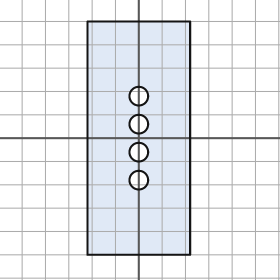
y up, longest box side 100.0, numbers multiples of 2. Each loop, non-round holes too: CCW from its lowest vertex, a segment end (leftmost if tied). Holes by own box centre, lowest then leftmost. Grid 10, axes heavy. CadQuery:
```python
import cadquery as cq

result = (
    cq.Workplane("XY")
    .moveTo(-22.0, -50.0)
    .lineTo(22.0, -50.0)
    .lineTo(22.0, 50.0)
    .lineTo(-22.0, 50.0)
    .close()
    .moveTo(0.0, -18.0)
    .circle(4.0)
    .moveTo(0.0, -6.0)
    .circle(4.0)
    .moveTo(0.0, 6.0)
    .circle(4.0)
    .moveTo(0.0, 18.0)
    .circle(4.0)
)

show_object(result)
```